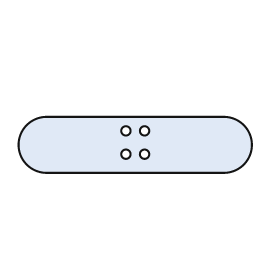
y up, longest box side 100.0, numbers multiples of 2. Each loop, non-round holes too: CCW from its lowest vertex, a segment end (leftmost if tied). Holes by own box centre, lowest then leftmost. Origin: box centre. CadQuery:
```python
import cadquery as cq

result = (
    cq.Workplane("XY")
    .moveTo(-38.0, -12.0)
    .lineTo(38.0, -12.0)
    .threePointArc((50.0, 0.0), (38.0, 12.0))
    .lineTo(-38.0, 12.0)
    .threePointArc((-50.0, 0.0), (-38.0, -12.0))
    .close()
    .moveTo(-4.0, -4.0)
    .circle(2.0)
    .moveTo(4.0, -4.0)
    .circle(2.0)
    .moveTo(-4.0, 6.0)
    .circle(2.0)
    .moveTo(4.0, 6.0)
    .circle(2.0)
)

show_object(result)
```